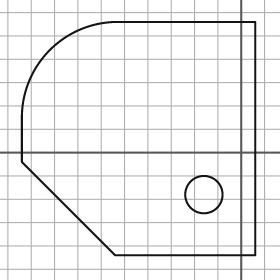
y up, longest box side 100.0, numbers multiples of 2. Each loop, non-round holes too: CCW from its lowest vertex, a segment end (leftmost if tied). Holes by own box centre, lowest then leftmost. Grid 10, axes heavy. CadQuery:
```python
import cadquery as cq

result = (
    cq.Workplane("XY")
    .moveTo(-54.0, -44.0)
    .lineTo(6.0, -44.0)
    .lineTo(6.0, 56.0)
    .lineTo(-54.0, 56.0)
    .threePointArc((-82.0, 44.0), (-94.0, 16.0))
    .lineTo(-94.0, -4.0)
    .close()
    .moveTo(-16.0, -18.0)
    .circle(8.0)
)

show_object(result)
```